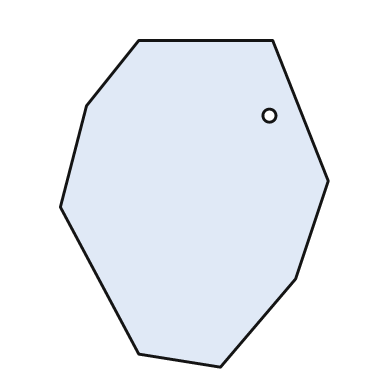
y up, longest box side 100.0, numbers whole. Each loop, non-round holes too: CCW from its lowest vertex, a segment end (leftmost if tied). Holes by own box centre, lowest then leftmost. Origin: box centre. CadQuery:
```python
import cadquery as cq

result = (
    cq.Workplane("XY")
    .moveTo(8.0, -50.0)
    .lineTo(31.0, -23.0)
    .lineTo(41.0, 7.0)
    .lineTo(24.0, 50.0)
    .lineTo(-17.0, 50.0)
    .lineTo(-33.0, 30.0)
    .lineTo(-41.0, -1.0)
    .lineTo(-17.0, -46.0)
    .close()
    .moveTo(23.0, 27.0)
    .circle(2.0)
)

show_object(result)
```